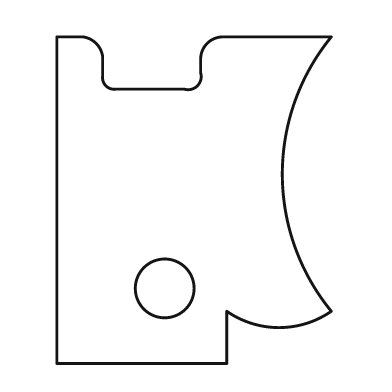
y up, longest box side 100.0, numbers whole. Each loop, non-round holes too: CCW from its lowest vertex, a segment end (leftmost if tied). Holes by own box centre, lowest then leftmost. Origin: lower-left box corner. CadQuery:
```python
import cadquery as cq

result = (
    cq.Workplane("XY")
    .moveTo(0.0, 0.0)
    .lineTo(52.0, 0.0)
    .lineTo(52.0, 16.0)
    .threePointArc((68.0, 11.0), (84.0, 16.0))
    .threePointArc((69.0, 58.0), (84.0, 100.0))
    .lineTo(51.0, 100.0)
    .threePointArc((46.0, 98.0), (44.0, 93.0))
    .lineTo(44.0, 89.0)
    .threePointArc((43.0, 85.0), (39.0, 84.0))
    .lineTo(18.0, 84.0)
    .threePointArc((15.0, 85.0), (14.0, 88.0))
    .lineTo(14.0, 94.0)
    .threePointArc((12.0, 98.0), (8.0, 100.0))
    .lineTo(0.0, 100.0)
    .close()
    .moveTo(33.0, 23.0)
    .circle(9.0)
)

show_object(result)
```